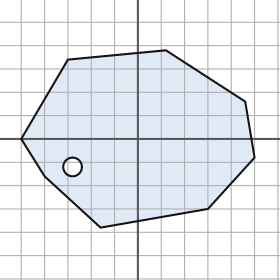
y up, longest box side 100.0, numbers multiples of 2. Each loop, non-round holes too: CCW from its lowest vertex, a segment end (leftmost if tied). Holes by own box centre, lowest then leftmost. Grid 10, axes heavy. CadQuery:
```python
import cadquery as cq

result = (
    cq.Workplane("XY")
    .moveTo(-16.0, -38.0)
    .lineTo(30.0, -30.0)
    .lineTo(50.0, -8.0)
    .lineTo(46.0, 16.0)
    .lineTo(12.0, 38.0)
    .lineTo(-30.0, 34.0)
    .lineTo(-50.0, 0.0)
    .lineTo(-40.0, -16.0)
    .close()
    .moveTo(-28.0, -12.0)
    .circle(4.0)
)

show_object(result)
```